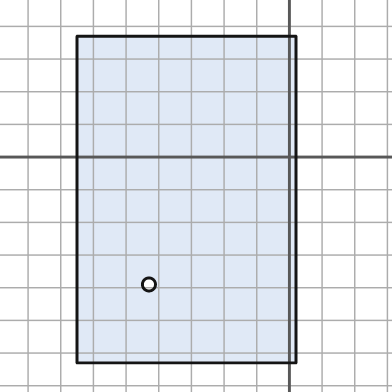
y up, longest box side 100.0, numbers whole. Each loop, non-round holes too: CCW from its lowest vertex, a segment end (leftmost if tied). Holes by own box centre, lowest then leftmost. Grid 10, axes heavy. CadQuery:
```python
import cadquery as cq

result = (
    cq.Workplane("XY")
    .moveTo(-65.0, -63.0)
    .lineTo(2.0, -63.0)
    .lineTo(2.0, 37.0)
    .lineTo(-65.0, 37.0)
    .close()
    .moveTo(-43.0, -39.0)
    .circle(2.0)
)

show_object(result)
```